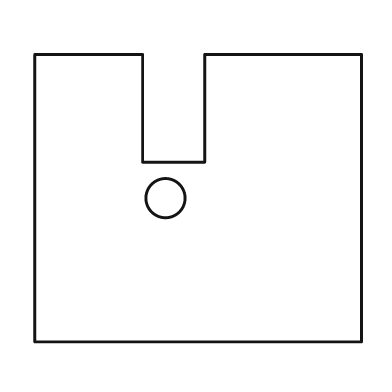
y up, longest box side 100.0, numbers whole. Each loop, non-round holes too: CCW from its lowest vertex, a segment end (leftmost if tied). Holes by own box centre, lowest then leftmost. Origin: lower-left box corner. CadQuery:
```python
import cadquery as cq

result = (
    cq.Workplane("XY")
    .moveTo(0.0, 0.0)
    .lineTo(100.0, 0.0)
    .lineTo(100.0, 88.0)
    .lineTo(52.0, 88.0)
    .lineTo(52.0, 55.0)
    .lineTo(33.0, 55.0)
    .lineTo(33.0, 88.0)
    .lineTo(0.0, 88.0)
    .close()
    .moveTo(40.0, 44.0)
    .circle(6.0)
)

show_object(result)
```